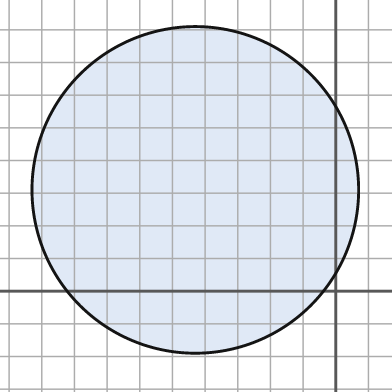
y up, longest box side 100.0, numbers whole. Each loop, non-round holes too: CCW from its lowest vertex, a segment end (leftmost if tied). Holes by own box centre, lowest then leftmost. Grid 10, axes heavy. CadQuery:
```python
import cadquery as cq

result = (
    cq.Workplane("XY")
    .moveTo(-43.0, 31.0)
    .circle(50.0)
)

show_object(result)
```